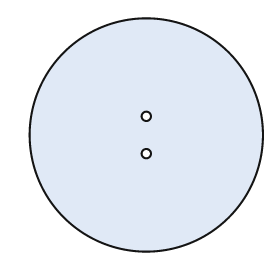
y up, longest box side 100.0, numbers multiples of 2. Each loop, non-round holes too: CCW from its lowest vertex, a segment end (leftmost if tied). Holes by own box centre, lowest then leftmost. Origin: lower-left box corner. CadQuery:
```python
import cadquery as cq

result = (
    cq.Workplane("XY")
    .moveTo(50.0, 50.0)
    .circle(50.0)
    .moveTo(50.0, 42.0)
    .circle(2.0)
    .moveTo(50.0, 58.0)
    .circle(2.0)
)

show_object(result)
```